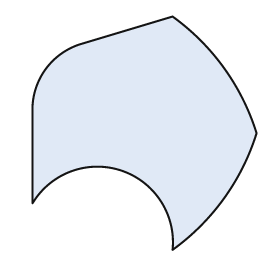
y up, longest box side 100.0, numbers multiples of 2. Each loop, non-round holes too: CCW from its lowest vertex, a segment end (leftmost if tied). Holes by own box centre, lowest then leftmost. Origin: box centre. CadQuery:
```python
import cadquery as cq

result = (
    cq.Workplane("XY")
    .moveTo(12.0, -50.0)
    .threePointArc((34.0, -28.0), (48.0, 0.0))
    .threePointArc((34.0, 28.0), (12.0, 50.0))
    .lineTo(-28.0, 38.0)
    .threePointArc((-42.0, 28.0), (-48.0, 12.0))
    .lineTo(-48.0, -30.0)
    .threePointArc((-10.0, -16.0), (12.0, -50.0))
    .close()
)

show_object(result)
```